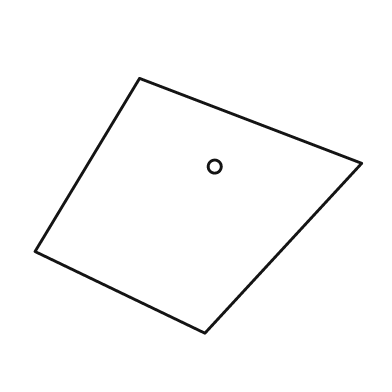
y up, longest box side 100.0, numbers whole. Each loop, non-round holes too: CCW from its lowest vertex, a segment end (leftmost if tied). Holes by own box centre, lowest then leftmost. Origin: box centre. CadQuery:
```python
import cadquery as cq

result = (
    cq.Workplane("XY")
    .moveTo(2.0, -39.0)
    .lineTo(50.0, 13.0)
    .lineTo(-18.0, 39.0)
    .lineTo(-50.0, -14.0)
    .close()
    .moveTo(5.0, 12.0)
    .circle(2.0)
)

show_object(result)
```